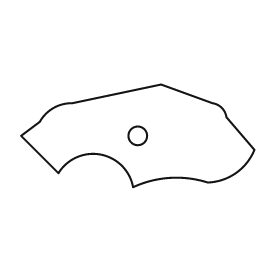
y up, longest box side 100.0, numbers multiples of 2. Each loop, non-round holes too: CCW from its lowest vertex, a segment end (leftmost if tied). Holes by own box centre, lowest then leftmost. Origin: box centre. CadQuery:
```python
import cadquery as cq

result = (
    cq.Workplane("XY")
    .moveTo(-2.0, -22.0)
    .threePointArc((14.0, -18.0), (30.0, -20.0))
    .threePointArc((42.0, -16.0), (50.0, -6.0))
    .lineTo(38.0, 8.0)
    .threePointArc((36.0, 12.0), (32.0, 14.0))
    .lineTo(10.0, 22.0)
    .lineTo(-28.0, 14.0)
    .threePointArc((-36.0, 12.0), (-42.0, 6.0))
    .lineTo(-50.0, 0.0)
    .lineTo(-34.0, -16.0)
    .threePointArc((-16.0, -8.0), (-2.0, -22.0))
    .close()
    .moveTo(0.0, 0.0)
    .circle(4.0)
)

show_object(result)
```